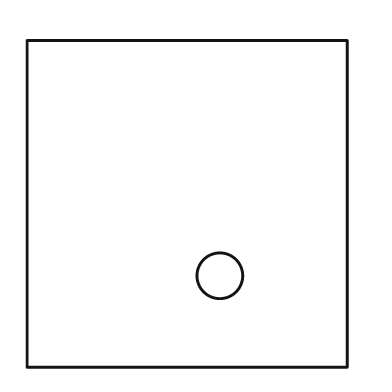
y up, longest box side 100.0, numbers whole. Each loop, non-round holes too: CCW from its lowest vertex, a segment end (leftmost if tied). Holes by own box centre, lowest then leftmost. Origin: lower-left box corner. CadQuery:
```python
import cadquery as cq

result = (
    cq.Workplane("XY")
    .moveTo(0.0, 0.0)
    .lineTo(98.0, 0.0)
    .lineTo(98.0, 100.0)
    .lineTo(0.0, 100.0)
    .close()
    .moveTo(59.0, 28.0)
    .circle(7.0)
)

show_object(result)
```